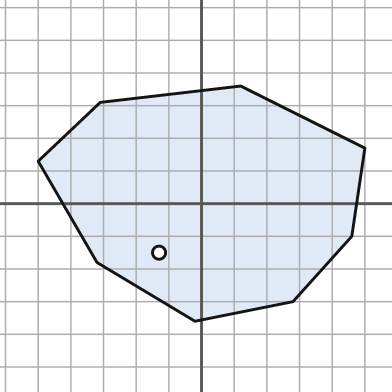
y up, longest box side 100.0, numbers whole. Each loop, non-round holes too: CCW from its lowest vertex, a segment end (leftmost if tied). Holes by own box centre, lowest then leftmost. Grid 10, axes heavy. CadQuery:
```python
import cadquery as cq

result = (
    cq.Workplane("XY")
    .moveTo(-2.0, -36.0)
    .lineTo(28.0, -30.0)
    .lineTo(46.0, -10.0)
    .lineTo(50.0, 17.0)
    .lineTo(12.0, 36.0)
    .lineTo(-31.0, 31.0)
    .lineTo(-50.0, 13.0)
    .lineTo(-32.0, -18.0)
    .close()
    .moveTo(-13.0, -15.0)
    .circle(2.0)
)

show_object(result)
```